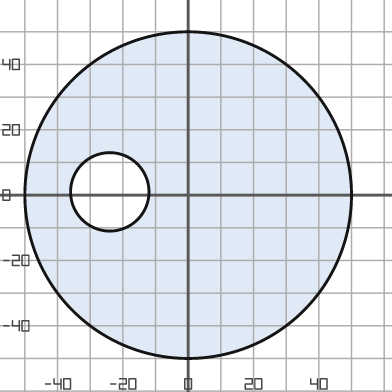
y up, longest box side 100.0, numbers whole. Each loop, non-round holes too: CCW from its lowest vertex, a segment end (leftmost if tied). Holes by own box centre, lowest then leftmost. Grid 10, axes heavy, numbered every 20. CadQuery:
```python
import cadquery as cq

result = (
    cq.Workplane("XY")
    .moveTo(0.0, 0.0)
    .circle(50.0)
    .moveTo(-24.0, 1.0)
    .circle(12.0)
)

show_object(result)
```